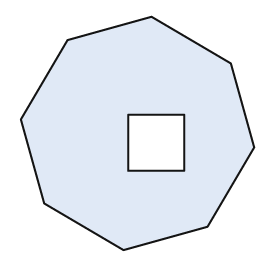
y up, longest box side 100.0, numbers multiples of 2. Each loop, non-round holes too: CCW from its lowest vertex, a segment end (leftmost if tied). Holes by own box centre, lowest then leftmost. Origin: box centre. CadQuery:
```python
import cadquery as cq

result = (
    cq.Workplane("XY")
    .moveTo(-6.0, -50.0)
    .lineTo(30.0, -40.0)
    .lineTo(50.0, -6.0)
    .lineTo(40.0, 30.0)
    .lineTo(6.0, 50.0)
    .lineTo(-30.0, 40.0)
    .lineTo(-50.0, 6.0)
    .lineTo(-40.0, -30.0)
    .close()
    .moveTo(-4.0, -16.0)
    .lineTo(20.0, -16.0)
    .lineTo(20.0, 8.0)
    .lineTo(-4.0, 8.0)
    .close()
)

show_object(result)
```